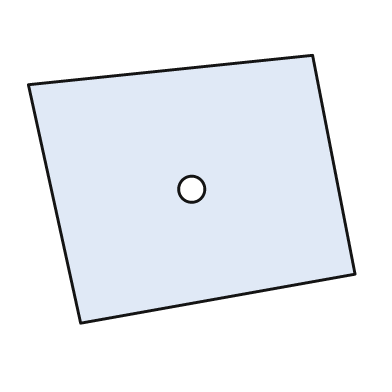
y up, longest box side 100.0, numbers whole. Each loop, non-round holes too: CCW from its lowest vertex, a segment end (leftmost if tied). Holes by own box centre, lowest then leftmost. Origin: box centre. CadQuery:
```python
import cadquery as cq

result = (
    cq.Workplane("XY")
    .moveTo(-34.0, -41.0)
    .lineTo(50.0, -26.0)
    .lineTo(37.0, 41.0)
    .lineTo(-50.0, 32.0)
    .close()
    .moveTo(0.0, 0.0)
    .circle(4.0)
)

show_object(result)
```